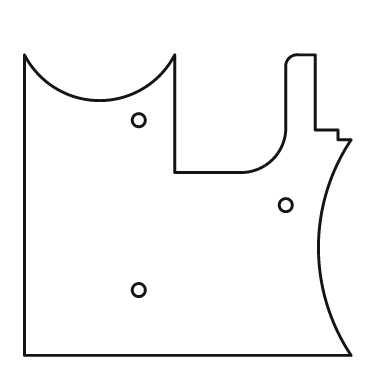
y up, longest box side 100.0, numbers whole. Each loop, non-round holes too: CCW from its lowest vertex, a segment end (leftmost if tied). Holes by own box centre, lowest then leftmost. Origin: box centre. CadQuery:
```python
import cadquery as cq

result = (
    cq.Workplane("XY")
    .moveTo(-50.0, -46.0)
    .lineTo(50.0, -46.0)
    .threePointArc((40.0, -13.0), (50.0, 20.0))
    .lineTo(46.0, 20.0)
    .lineTo(46.0, 23.0)
    .lineTo(39.0, 23.0)
    .lineTo(39.0, 46.0)
    .lineTo(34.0, 46.0)
    .threePointArc((31.0, 45.0), (30.0, 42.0))
    .lineTo(30.0, 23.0)
    .threePointArc((26.0, 14.0), (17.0, 10.0))
    .lineTo(-4.0, 10.0)
    .lineTo(-4.0, 46.0)
    .threePointArc((-27.0, 32.0), (-50.0, 46.0))
    .close()
    .moveTo(-15.0, -26.0)
    .circle(2.0)
    .moveTo(30.0, 0.0)
    .circle(2.0)
    .moveTo(-15.0, 26.0)
    .circle(2.0)
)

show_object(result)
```